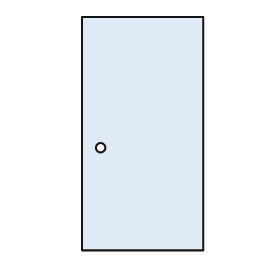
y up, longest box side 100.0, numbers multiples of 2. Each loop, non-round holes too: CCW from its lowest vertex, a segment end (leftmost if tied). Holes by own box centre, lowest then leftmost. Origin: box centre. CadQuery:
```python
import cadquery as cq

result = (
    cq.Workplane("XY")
    .moveTo(-26.0, -50.0)
    .lineTo(26.0, -50.0)
    .lineTo(26.0, 50.0)
    .lineTo(-26.0, 50.0)
    .close()
    .moveTo(-18.0, -6.0)
    .circle(2.0)
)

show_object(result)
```